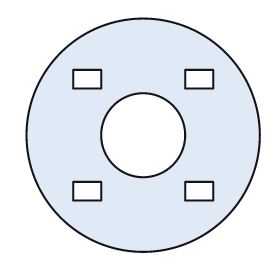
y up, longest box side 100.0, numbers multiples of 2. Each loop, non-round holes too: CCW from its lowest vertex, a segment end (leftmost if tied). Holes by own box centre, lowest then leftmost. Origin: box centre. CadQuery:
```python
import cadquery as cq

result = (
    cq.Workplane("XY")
    .moveTo(0.0, 0.0)
    .circle(50.0)
    .moveTo(-30.0, -28.0)
    .lineTo(-18.0, -28.0)
    .lineTo(-18.0, -20.0)
    .lineTo(-30.0, -20.0)
    .close()
    .moveTo(18.0, -28.0)
    .lineTo(30.0, -28.0)
    .lineTo(30.0, -20.0)
    .lineTo(18.0, -20.0)
    .close()
    .moveTo(0.0, 0.0)
    .circle(18.0)
    .moveTo(-30.0, 20.0)
    .lineTo(-18.0, 20.0)
    .lineTo(-18.0, 28.0)
    .lineTo(-30.0, 28.0)
    .close()
    .moveTo(18.0, 20.0)
    .lineTo(30.0, 20.0)
    .lineTo(30.0, 28.0)
    .lineTo(18.0, 28.0)
    .close()
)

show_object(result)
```